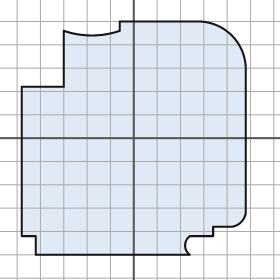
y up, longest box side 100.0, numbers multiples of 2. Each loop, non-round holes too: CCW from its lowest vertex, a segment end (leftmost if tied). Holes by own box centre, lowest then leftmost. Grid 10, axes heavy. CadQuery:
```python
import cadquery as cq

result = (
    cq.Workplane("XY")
    .moveTo(-42.0, -50.0)
    .lineTo(24.0, -50.0)
    .threePointArc((22.0, -46.0), (24.0, -42.0))
    .lineTo(34.0, -42.0)
    .lineTo(34.0, -38.0)
    .lineTo(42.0, -38.0)
    .threePointArc((46.0, -36.0), (48.0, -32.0))
    .lineTo(48.0, 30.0)
    .threePointArc((42.0, 44.0), (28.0, 50.0))
    .lineTo(-6.0, 50.0)
    .lineTo(-6.0, 46.0)
    .threePointArc((-18.0, 44.0), (-30.0, 46.0))
    .lineTo(-30.0, 22.0)
    .lineTo(-48.0, 22.0)
    .lineTo(-48.0, -42.0)
    .lineTo(-42.0, -42.0)
    .close()
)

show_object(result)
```